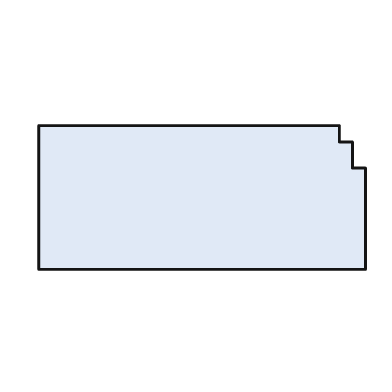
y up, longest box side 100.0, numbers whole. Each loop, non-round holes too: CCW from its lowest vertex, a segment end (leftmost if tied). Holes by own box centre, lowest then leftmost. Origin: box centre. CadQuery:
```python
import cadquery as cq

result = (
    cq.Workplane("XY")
    .moveTo(-50.0, -22.0)
    .lineTo(50.0, -22.0)
    .lineTo(50.0, 9.0)
    .lineTo(46.0, 9.0)
    .lineTo(46.0, 17.0)
    .lineTo(42.0, 17.0)
    .lineTo(42.0, 22.0)
    .lineTo(-50.0, 22.0)
    .close()
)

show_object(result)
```